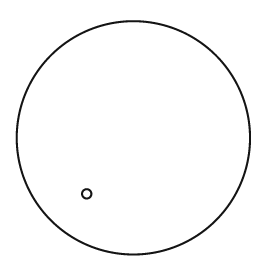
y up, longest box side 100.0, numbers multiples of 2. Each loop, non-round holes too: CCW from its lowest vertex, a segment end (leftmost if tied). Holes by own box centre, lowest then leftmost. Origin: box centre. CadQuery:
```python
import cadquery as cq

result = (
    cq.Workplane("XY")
    .moveTo(0.0, 0.0)
    .circle(50.0)
    .moveTo(-20.0, -24.0)
    .circle(2.0)
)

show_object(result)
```